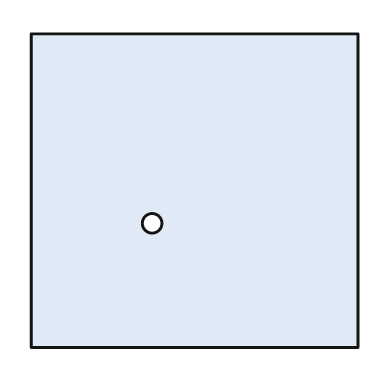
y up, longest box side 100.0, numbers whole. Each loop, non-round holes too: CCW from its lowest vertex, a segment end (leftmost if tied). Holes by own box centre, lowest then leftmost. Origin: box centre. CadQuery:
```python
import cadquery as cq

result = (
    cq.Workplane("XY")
    .moveTo(-50.0, -48.0)
    .lineTo(50.0, -48.0)
    .lineTo(50.0, 48.0)
    .lineTo(-50.0, 48.0)
    .close()
    .moveTo(-13.0, -10.0)
    .circle(3.0)
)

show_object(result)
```